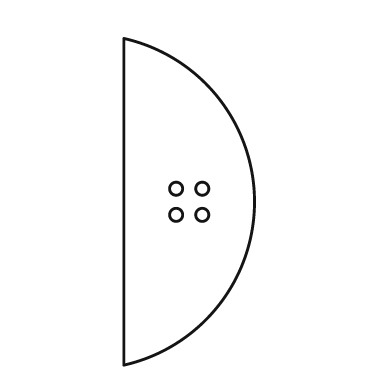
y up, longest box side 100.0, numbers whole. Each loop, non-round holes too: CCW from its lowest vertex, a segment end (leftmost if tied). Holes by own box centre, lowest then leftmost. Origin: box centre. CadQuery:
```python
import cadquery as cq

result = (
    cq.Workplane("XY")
    .moveTo(-20.0, -50.0)
    .threePointArc((20.0, 0.0), (-20.0, 50.0))
    .close()
    .moveTo(-4.0, -4.0)
    .circle(2.0)
    .moveTo(4.0, -4.0)
    .circle(2.0)
    .moveTo(-4.0, 4.0)
    .circle(2.0)
    .moveTo(4.0, 4.0)
    .circle(2.0)
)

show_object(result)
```